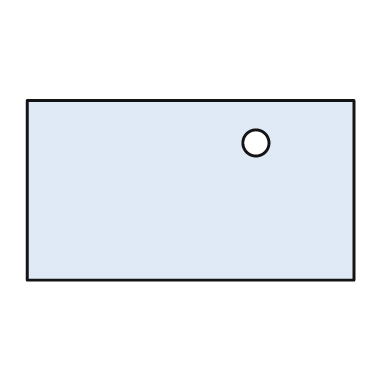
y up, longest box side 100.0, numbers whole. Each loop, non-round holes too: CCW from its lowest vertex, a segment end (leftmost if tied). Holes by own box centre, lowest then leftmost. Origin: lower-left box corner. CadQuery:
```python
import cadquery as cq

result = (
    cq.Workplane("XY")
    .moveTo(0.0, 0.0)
    .lineTo(100.0, 0.0)
    .lineTo(100.0, 55.0)
    .lineTo(0.0, 55.0)
    .close()
    .moveTo(70.0, 42.0)
    .circle(4.0)
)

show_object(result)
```